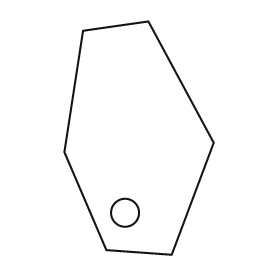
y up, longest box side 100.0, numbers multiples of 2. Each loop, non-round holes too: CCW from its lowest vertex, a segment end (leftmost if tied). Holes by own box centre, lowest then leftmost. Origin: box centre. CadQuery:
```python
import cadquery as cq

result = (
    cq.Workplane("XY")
    .moveTo(14.0, -50.0)
    .lineTo(32.0, -2.0)
    .lineTo(4.0, 50.0)
    .lineTo(-24.0, 46.0)
    .lineTo(-32.0, -6.0)
    .lineTo(-14.0, -48.0)
    .close()
    .moveTo(-6.0, -32.0)
    .circle(6.0)
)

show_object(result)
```